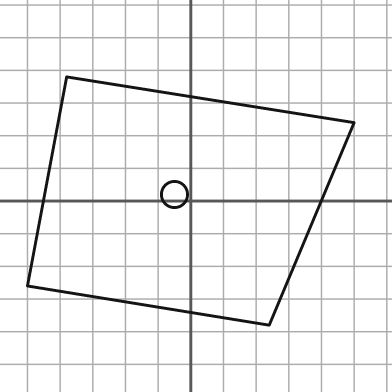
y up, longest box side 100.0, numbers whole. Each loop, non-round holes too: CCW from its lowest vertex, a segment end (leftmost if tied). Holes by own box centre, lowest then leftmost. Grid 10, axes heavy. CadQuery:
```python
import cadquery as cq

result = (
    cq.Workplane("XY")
    .moveTo(24.0, -38.0)
    .lineTo(50.0, 24.0)
    .lineTo(-38.0, 38.0)
    .lineTo(-50.0, -26.0)
    .close()
    .moveTo(-5.0, 2.0)
    .circle(4.0)
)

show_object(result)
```